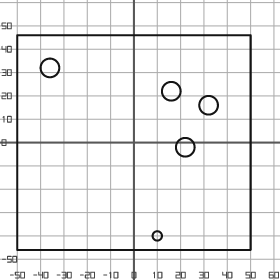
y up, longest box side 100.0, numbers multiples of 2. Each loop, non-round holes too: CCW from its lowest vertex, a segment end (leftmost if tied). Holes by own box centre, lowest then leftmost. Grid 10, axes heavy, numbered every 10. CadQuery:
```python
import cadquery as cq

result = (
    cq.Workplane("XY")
    .moveTo(-50.0, -46.0)
    .lineTo(50.0, -46.0)
    .lineTo(50.0, 46.0)
    .lineTo(-50.0, 46.0)
    .close()
    .moveTo(10.0, -40.0)
    .circle(2.0)
    .moveTo(22.0, -2.0)
    .circle(4.0)
    .moveTo(32.0, 16.0)
    .circle(4.0)
    .moveTo(16.0, 22.0)
    .circle(4.0)
    .moveTo(-36.0, 32.0)
    .circle(4.0)
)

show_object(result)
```